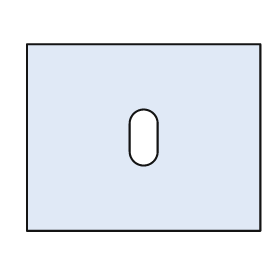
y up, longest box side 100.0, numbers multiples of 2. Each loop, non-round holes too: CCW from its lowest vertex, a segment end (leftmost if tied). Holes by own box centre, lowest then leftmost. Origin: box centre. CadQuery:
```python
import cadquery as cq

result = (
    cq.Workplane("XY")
    .moveTo(-50.0, -40.0)
    .lineTo(50.0, -40.0)
    .lineTo(50.0, 40.0)
    .lineTo(-50.0, 40.0)
    .close()
    .moveTo(-6.0, -6.0)
    .threePointArc((0.0, -12.0), (6.0, -6.0))
    .lineTo(6.0, 6.0)
    .threePointArc((0.0, 12.0), (-6.0, 6.0))
    .close()
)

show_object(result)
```